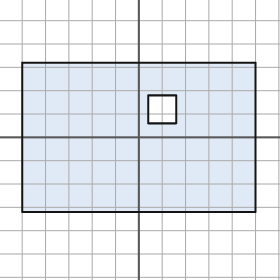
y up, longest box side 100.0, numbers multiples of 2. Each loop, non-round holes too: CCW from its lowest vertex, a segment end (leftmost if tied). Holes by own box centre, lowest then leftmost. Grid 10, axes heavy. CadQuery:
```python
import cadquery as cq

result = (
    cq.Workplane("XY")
    .moveTo(-50.0, -32.0)
    .lineTo(50.0, -32.0)
    .lineTo(50.0, 32.0)
    .lineTo(-50.0, 32.0)
    .close()
    .moveTo(4.0, 6.0)
    .lineTo(16.0, 6.0)
    .lineTo(16.0, 18.0)
    .lineTo(4.0, 18.0)
    .close()
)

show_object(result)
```